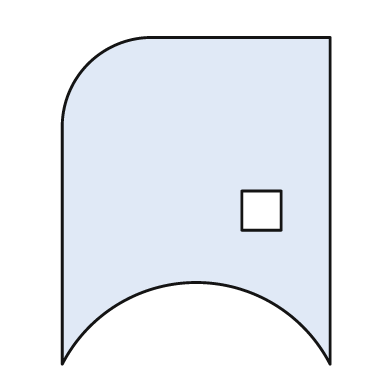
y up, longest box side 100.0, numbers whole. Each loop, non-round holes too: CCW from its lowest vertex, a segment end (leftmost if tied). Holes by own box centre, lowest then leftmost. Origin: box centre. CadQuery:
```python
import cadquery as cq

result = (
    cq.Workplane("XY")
    .moveTo(-41.0, -50.0)
    .threePointArc((0.0, -25.0), (41.0, -50.0))
    .lineTo(41.0, 50.0)
    .lineTo(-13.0, 50.0)
    .threePointArc((-33.0, 42.0), (-41.0, 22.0))
    .close()
    .moveTo(14.0, -9.0)
    .lineTo(26.0, -9.0)
    .lineTo(26.0, 3.0)
    .lineTo(14.0, 3.0)
    .close()
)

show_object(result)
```